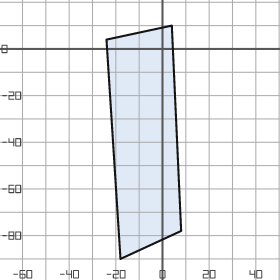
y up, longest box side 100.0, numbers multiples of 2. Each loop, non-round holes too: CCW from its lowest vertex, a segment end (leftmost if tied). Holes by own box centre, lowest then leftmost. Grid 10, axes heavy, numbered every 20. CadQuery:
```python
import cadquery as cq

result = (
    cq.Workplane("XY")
    .moveTo(-18.0, -90.0)
    .lineTo(8.0, -78.0)
    .lineTo(4.0, 10.0)
    .lineTo(-24.0, 4.0)
    .close()
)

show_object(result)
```